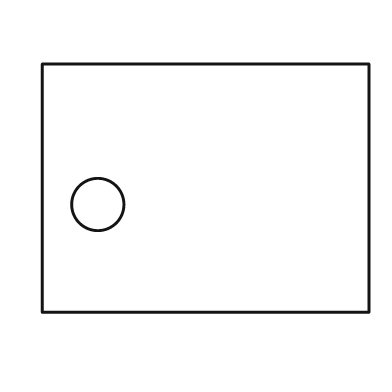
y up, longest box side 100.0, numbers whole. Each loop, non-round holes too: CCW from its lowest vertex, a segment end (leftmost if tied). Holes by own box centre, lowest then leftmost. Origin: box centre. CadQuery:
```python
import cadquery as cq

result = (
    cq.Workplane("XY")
    .moveTo(-50.0, -38.0)
    .lineTo(50.0, -38.0)
    .lineTo(50.0, 38.0)
    .lineTo(-50.0, 38.0)
    .close()
    .moveTo(-33.0, -5.0)
    .circle(8.0)
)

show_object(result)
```